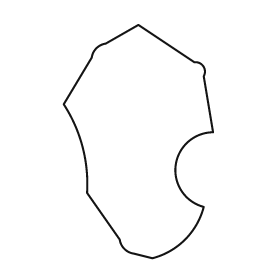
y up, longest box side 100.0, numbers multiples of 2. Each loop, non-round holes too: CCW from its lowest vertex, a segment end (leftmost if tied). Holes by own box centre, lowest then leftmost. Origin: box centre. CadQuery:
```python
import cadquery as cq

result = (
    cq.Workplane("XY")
    .moveTo(6.0, -50.0)
    .threePointArc((20.0, -42.0), (28.0, -28.0))
    .threePointArc((16.0, -10.0), (32.0, 4.0))
    .lineTo(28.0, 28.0)
    .threePointArc((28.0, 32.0), (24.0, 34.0))
    .lineTo(0.0, 50.0)
    .lineTo(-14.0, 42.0)
    .threePointArc((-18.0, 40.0), (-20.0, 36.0))
    .lineTo(-32.0, 16.0)
    .threePointArc((-24.0, -2.0), (-22.0, -22.0))
    .lineTo(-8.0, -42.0)
    .threePointArc((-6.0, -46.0), (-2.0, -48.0))
    .close()
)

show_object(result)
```